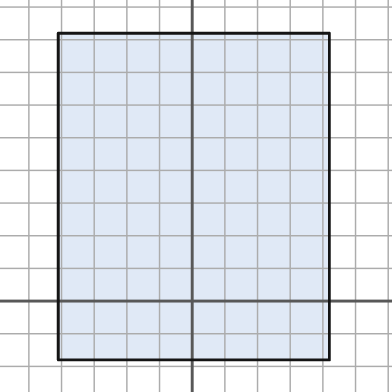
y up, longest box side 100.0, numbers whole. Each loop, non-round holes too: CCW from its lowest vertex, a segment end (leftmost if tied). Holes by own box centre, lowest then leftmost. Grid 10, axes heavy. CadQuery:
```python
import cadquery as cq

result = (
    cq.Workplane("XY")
    .moveTo(-41.0, -18.0)
    .lineTo(42.0, -18.0)
    .lineTo(42.0, 82.0)
    .lineTo(-41.0, 82.0)
    .close()
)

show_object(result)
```